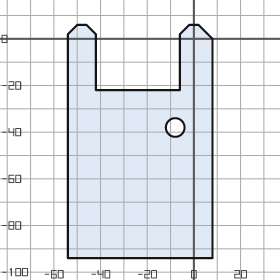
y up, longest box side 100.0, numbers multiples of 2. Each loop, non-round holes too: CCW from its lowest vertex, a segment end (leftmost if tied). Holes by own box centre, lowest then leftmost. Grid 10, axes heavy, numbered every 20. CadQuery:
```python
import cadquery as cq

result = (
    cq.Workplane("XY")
    .moveTo(-54.0, -94.0)
    .lineTo(8.0, -94.0)
    .lineTo(8.0, 0.0)
    .lineTo(2.0, 6.0)
    .lineTo(-2.0, 6.0)
    .lineTo(-6.0, 2.0)
    .lineTo(-6.0, -22.0)
    .lineTo(-42.0, -22.0)
    .lineTo(-42.0, 2.0)
    .lineTo(-46.0, 6.0)
    .lineTo(-50.0, 6.0)
    .lineTo(-54.0, 2.0)
    .close()
    .moveTo(-8.0, -38.0)
    .circle(4.0)
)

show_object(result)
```